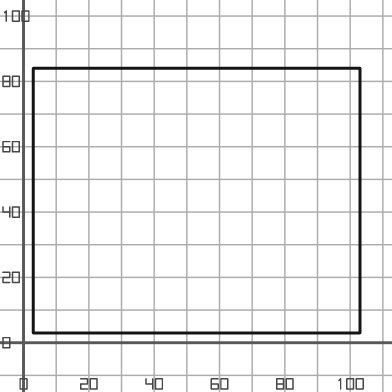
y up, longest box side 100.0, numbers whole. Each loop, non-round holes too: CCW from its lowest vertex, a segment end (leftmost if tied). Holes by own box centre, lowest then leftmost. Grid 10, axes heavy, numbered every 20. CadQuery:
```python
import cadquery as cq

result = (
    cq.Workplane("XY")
    .moveTo(3.0, 3.0)
    .lineTo(103.0, 3.0)
    .lineTo(103.0, 84.0)
    .lineTo(3.0, 84.0)
    .close()
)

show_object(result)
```